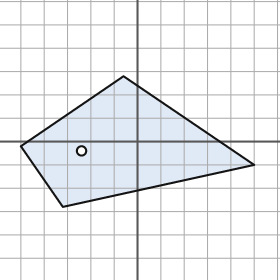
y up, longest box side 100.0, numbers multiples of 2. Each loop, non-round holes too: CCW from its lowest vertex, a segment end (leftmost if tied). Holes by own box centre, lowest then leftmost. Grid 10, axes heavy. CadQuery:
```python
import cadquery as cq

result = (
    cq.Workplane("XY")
    .moveTo(-32.0, -28.0)
    .lineTo(50.0, -10.0)
    .lineTo(-6.0, 28.0)
    .lineTo(-50.0, -2.0)
    .close()
    .moveTo(-24.0, -4.0)
    .circle(2.0)
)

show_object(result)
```